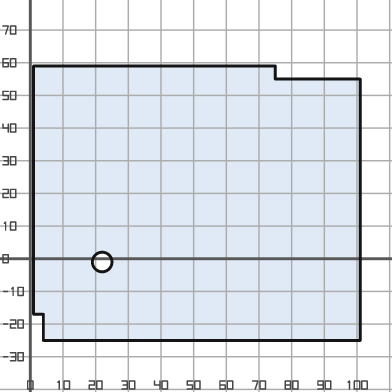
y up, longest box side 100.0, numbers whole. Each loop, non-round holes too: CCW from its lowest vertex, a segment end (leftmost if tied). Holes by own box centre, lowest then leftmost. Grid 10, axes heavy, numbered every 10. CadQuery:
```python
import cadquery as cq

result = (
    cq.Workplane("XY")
    .moveTo(4.0, -25.0)
    .lineTo(101.0, -25.0)
    .lineTo(101.0, 55.0)
    .lineTo(75.0, 55.0)
    .lineTo(75.0, 59.0)
    .lineTo(1.0, 59.0)
    .lineTo(1.0, -17.0)
    .lineTo(4.0, -17.0)
    .close()
    .moveTo(22.0, -1.0)
    .circle(3.0)
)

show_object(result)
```